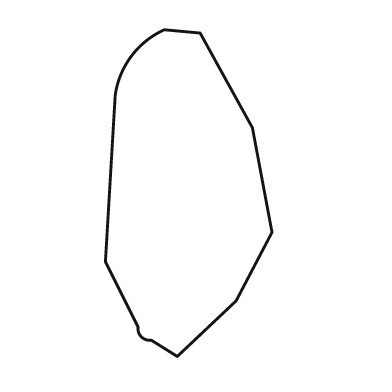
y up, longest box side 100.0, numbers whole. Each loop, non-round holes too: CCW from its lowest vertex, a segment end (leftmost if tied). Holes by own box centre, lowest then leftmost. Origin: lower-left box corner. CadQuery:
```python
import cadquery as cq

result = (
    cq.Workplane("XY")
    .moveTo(22.0, 0.0)
    .lineTo(40.0, 17.0)
    .lineTo(51.0, 38.0)
    .lineTo(45.0, 70.0)
    .lineTo(29.0, 99.0)
    .lineTo(18.0, 100.0)
    .threePointArc((8.0, 92.0), (3.0, 80.0))
    .lineTo(0.0, 29.0)
    .lineTo(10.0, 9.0)
    .threePointArc((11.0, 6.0), (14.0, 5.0))
    .close()
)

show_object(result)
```